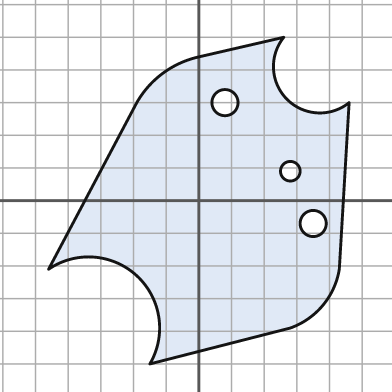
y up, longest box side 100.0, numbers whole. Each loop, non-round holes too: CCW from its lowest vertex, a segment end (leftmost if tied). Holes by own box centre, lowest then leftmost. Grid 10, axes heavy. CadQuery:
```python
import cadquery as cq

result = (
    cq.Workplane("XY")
    .moveTo(-15.0, -50.0)
    .lineTo(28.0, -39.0)
    .threePointArc((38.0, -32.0), (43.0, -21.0))
    .lineTo(46.0, 30.0)
    .threePointArc((27.0, 31.0), (26.0, 50.0))
    .lineTo(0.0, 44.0)
    .threePointArc((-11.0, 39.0), (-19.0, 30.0))
    .lineTo(-46.0, -21.0)
    .threePointArc((-19.0, -23.0), (-15.0, -50.0))
    .close()
    .moveTo(35.0, -7.0)
    .circle(4.0)
    .moveTo(28.0, 9.0)
    .circle(3.0)
    .moveTo(8.0, 30.0)
    .circle(4.0)
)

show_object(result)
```